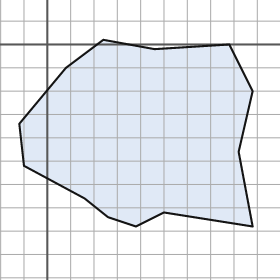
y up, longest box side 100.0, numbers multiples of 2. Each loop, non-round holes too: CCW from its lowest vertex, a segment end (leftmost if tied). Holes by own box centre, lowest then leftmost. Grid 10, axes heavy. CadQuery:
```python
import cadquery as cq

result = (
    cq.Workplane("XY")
    .moveTo(38.0, -78.0)
    .lineTo(50.0, -72.0)
    .lineTo(88.0, -78.0)
    .lineTo(82.0, -46.0)
    .lineTo(88.0, -20.0)
    .lineTo(78.0, 0.0)
    .lineTo(46.0, -2.0)
    .lineTo(24.0, 2.0)
    .lineTo(8.0, -10.0)
    .lineTo(-12.0, -34.0)
    .lineTo(-10.0, -52.0)
    .lineTo(16.0, -66.0)
    .lineTo(26.0, -74.0)
    .close()
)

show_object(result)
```